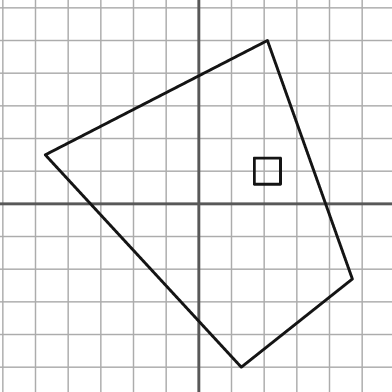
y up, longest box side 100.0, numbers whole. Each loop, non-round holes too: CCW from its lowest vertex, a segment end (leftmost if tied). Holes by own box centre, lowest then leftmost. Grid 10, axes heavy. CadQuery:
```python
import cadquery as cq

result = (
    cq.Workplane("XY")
    .moveTo(13.0, -50.0)
    .lineTo(47.0, -23.0)
    .lineTo(21.0, 50.0)
    .lineTo(-47.0, 15.0)
    .close()
    .moveTo(17.0, 6.0)
    .lineTo(25.0, 6.0)
    .lineTo(25.0, 14.0)
    .lineTo(17.0, 14.0)
    .close()
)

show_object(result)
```